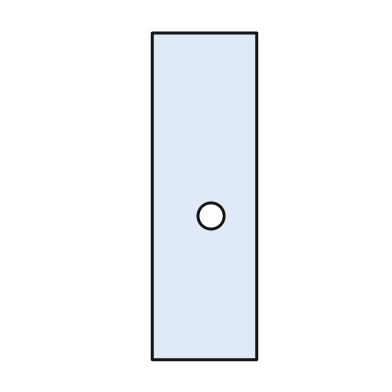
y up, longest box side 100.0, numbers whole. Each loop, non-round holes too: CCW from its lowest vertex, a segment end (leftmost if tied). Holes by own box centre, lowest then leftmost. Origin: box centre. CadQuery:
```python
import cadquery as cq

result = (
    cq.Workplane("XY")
    .moveTo(-16.0, -50.0)
    .lineTo(16.0, -50.0)
    .lineTo(16.0, 50.0)
    .lineTo(-16.0, 50.0)
    .close()
    .moveTo(2.0, -6.0)
    .circle(4.0)
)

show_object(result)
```